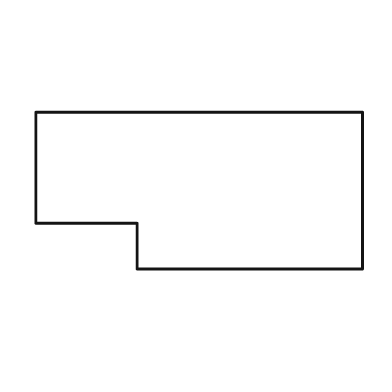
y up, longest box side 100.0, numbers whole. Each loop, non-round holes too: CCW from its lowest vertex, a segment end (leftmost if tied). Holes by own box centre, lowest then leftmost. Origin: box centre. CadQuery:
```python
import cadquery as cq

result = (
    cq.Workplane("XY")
    .moveTo(-19.0, -24.0)
    .lineTo(50.0, -24.0)
    .lineTo(50.0, 24.0)
    .lineTo(-50.0, 24.0)
    .lineTo(-50.0, -10.0)
    .lineTo(-19.0, -10.0)
    .close()
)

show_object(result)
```